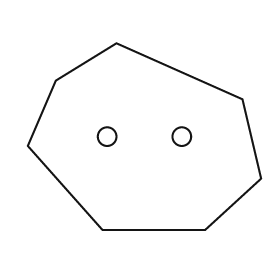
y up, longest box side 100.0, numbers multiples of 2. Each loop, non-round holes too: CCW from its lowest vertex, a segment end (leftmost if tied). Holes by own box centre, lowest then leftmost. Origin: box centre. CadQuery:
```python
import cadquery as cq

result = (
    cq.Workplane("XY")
    .moveTo(-18.0, -40.0)
    .lineTo(26.0, -40.0)
    .lineTo(50.0, -18.0)
    .lineTo(42.0, 16.0)
    .lineTo(-12.0, 40.0)
    .lineTo(-38.0, 24.0)
    .lineTo(-50.0, -4.0)
    .close()
    .moveTo(-16.0, 0.0)
    .circle(4.0)
    .moveTo(16.0, 0.0)
    .circle(4.0)
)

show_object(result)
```